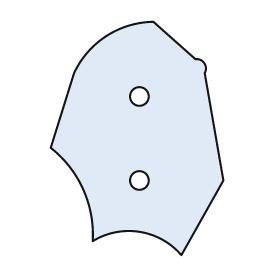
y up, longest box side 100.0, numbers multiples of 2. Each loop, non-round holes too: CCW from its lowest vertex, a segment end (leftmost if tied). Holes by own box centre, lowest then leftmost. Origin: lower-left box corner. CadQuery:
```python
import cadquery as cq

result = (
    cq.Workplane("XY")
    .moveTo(56.0, 0.0)
    .lineTo(74.0, 32.0)
    .lineTo(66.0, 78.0)
    .threePointArc((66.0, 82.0), (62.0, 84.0))
    .lineTo(44.0, 100.0)
    .threePointArc((24.0, 94.0), (10.0, 78.0))
    .lineTo(0.0, 46.0)
    .threePointArc((14.0, 28.0), (18.0, 6.0))
    .threePointArc((38.0, 10.0), (56.0, 0.0))
    .close()
    .moveTo(38.0, 32.0)
    .circle(4.0)
    .moveTo(38.0, 68.0)
    .circle(4.0)
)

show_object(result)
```